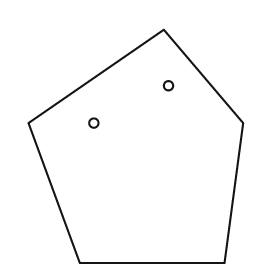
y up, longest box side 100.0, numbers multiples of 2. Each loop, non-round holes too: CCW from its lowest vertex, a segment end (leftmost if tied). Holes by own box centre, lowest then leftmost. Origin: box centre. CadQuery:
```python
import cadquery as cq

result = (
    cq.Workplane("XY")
    .moveTo(-24.0, -50.0)
    .lineTo(38.0, -50.0)
    .lineTo(46.0, 10.0)
    .lineTo(12.0, 50.0)
    .lineTo(-46.0, 10.0)
    .close()
    .moveTo(-18.0, 10.0)
    .circle(2.0)
    .moveTo(14.0, 26.0)
    .circle(2.0)
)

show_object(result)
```